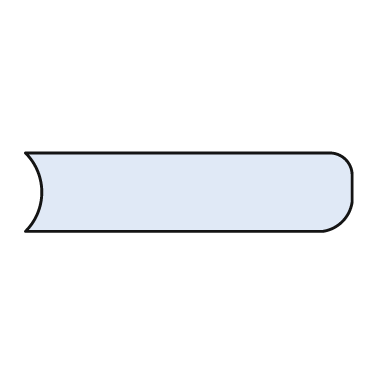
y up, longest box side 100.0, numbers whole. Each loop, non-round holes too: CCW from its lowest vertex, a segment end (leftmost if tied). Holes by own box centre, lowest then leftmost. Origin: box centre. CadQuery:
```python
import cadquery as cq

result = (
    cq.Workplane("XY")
    .moveTo(-50.0, -12.0)
    .lineTo(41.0, -12.0)
    .threePointArc((47.0, -9.0), (50.0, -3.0))
    .lineTo(50.0, 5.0)
    .threePointArc((48.0, 10.0), (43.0, 12.0))
    .lineTo(-50.0, 12.0)
    .threePointArc((-45.0, 0.0), (-50.0, -12.0))
    .close()
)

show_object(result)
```